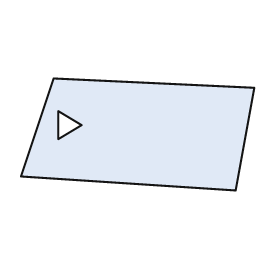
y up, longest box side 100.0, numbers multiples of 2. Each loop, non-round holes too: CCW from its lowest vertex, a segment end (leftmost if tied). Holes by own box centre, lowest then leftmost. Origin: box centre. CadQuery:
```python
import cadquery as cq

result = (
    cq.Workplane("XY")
    .moveTo(42.0, -24.0)
    .lineTo(50.0, 20.0)
    .lineTo(-36.0, 24.0)
    .lineTo(-50.0, -18.0)
    .close()
    .moveTo(-34.0, -2.0)
    .lineTo(-24.0, 4.0)
    .lineTo(-34.0, 10.0)
    .close()
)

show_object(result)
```